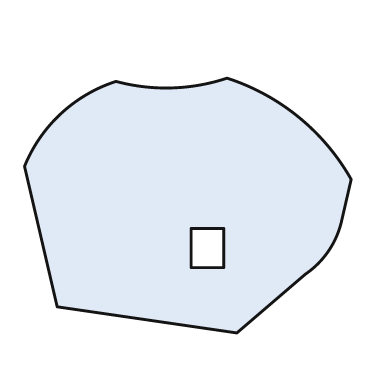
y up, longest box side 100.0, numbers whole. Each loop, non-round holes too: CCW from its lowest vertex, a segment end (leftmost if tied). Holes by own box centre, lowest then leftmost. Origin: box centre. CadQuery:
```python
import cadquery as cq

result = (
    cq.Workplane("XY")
    .moveTo(15.0, -39.0)
    .lineTo(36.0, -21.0)
    .threePointArc((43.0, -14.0), (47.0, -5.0))
    .lineTo(50.0, 8.0)
    .threePointArc((34.0, 27.0), (12.0, 39.0))
    .threePointArc((-5.0, 36.0), (-22.0, 38.0))
    .threePointArc((-39.0, 28.0), (-50.0, 12.0))
    .lineTo(-40.0, -31.0)
    .close()
    .moveTo(1.0, -19.0)
    .lineTo(11.0, -19.0)
    .lineTo(11.0, -7.0)
    .lineTo(1.0, -7.0)
    .close()
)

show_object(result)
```